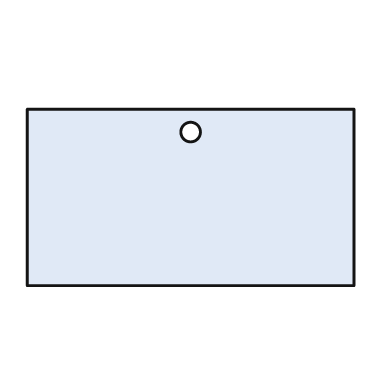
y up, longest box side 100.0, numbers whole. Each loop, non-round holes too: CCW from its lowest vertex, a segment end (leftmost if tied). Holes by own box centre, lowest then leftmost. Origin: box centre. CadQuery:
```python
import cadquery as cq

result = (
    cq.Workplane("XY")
    .moveTo(-50.0, -27.0)
    .lineTo(50.0, -27.0)
    .lineTo(50.0, 27.0)
    .lineTo(-50.0, 27.0)
    .close()
    .moveTo(0.0, 20.0)
    .circle(3.0)
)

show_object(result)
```